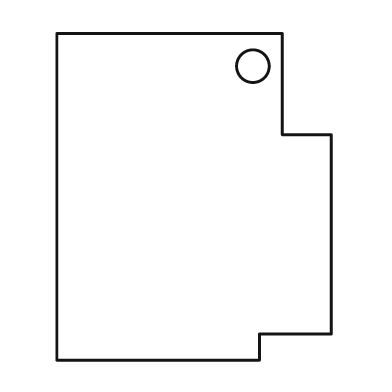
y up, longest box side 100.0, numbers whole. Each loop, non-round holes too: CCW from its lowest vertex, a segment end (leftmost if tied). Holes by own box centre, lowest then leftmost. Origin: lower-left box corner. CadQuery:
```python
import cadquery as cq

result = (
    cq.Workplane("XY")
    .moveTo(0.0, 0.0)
    .lineTo(62.0, 0.0)
    .lineTo(62.0, 8.0)
    .lineTo(84.0, 8.0)
    .lineTo(84.0, 69.0)
    .lineTo(69.0, 69.0)
    .lineTo(69.0, 100.0)
    .lineTo(0.0, 100.0)
    .close()
    .moveTo(60.0, 90.0)
    .circle(5.0)
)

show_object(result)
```